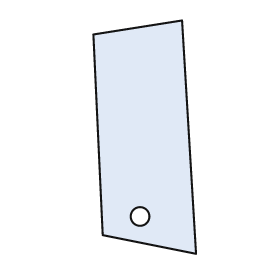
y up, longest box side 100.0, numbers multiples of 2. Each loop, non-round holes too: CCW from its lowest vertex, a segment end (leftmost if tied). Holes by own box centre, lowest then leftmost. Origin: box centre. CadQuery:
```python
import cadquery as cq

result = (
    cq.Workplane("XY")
    .moveTo(22.0, -50.0)
    .lineTo(16.0, 50.0)
    .lineTo(-22.0, 44.0)
    .lineTo(-18.0, -42.0)
    .close()
    .moveTo(-2.0, -34.0)
    .circle(4.0)
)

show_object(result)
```